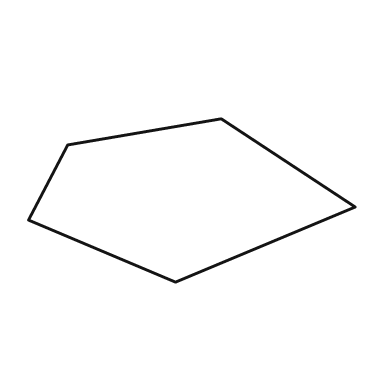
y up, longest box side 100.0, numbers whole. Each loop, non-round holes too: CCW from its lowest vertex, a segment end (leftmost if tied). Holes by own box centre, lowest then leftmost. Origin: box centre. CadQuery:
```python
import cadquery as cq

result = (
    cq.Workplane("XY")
    .moveTo(-5.0, -25.0)
    .lineTo(50.0, -2.0)
    .lineTo(9.0, 25.0)
    .lineTo(-38.0, 17.0)
    .lineTo(-50.0, -6.0)
    .close()
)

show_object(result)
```